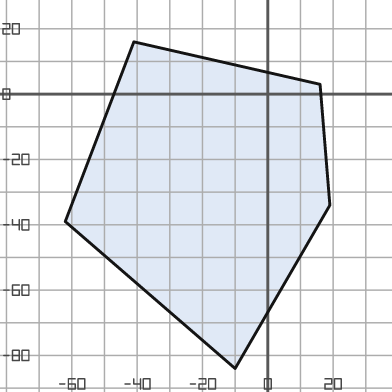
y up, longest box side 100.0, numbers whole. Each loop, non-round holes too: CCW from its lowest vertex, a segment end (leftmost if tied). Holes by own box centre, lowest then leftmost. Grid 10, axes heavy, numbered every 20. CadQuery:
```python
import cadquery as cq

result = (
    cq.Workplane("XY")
    .moveTo(-10.0, -84.0)
    .lineTo(19.0, -34.0)
    .lineTo(16.0, 3.0)
    .lineTo(-41.0, 16.0)
    .lineTo(-62.0, -39.0)
    .close()
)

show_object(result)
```